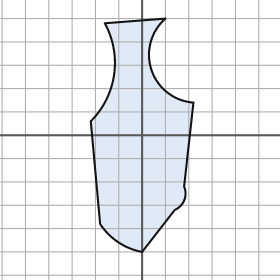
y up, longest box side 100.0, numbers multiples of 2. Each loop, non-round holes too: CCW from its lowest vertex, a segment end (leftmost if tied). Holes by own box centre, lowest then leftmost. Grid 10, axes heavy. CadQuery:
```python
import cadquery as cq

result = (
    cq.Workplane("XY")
    .moveTo(0.0, -50.0)
    .lineTo(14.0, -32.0)
    .threePointArc((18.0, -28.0), (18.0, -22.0))
    .lineTo(22.0, 14.0)
    .threePointArc((4.0, 28.0), (10.0, 50.0))
    .lineTo(-16.0, 48.0)
    .threePointArc((-12.0, 26.0), (-22.0, 6.0))
    .lineTo(-18.0, -38.0)
    .threePointArc((-10.0, -46.0), (0.0, -50.0))
    .close()
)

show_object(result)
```